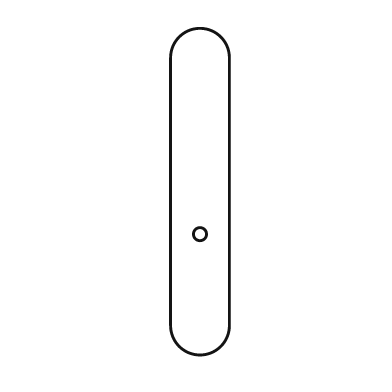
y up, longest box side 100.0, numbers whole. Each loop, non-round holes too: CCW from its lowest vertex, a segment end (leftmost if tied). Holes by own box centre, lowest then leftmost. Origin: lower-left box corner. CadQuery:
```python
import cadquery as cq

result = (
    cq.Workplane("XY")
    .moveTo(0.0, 9.0)
    .threePointArc((9.0, 0.0), (18.0, 9.0))
    .lineTo(18.0, 91.0)
    .threePointArc((9.0, 100.0), (0.0, 91.0))
    .close()
    .moveTo(9.0, 37.0)
    .circle(2.0)
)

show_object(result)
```